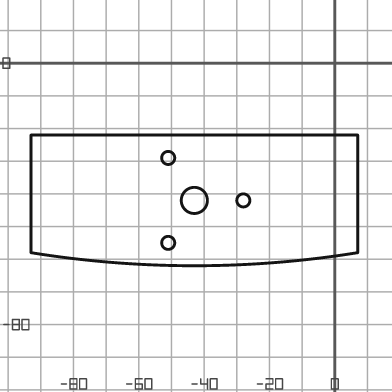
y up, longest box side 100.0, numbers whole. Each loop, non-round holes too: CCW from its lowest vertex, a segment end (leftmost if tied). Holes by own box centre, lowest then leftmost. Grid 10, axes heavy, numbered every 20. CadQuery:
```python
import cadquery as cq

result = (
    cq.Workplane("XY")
    .moveTo(-93.0, -58.0)
    .threePointArc((-43.0, -62.0), (7.0, -58.0))
    .lineTo(7.0, -22.0)
    .lineTo(-93.0, -22.0)
    .close()
    .moveTo(-51.0, -55.0)
    .circle(2.0)
    .moveTo(-43.0, -42.0)
    .circle(4.0)
    .moveTo(-28.0, -42.0)
    .circle(2.0)
    .moveTo(-51.0, -29.0)
    .circle(2.0)
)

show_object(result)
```